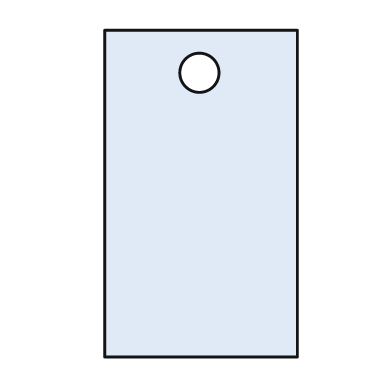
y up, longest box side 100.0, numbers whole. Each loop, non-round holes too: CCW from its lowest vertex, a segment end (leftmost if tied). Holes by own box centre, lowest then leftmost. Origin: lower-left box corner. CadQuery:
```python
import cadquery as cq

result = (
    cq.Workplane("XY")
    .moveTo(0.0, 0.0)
    .lineTo(59.0, 0.0)
    .lineTo(59.0, 100.0)
    .lineTo(0.0, 100.0)
    .close()
    .moveTo(29.0, 87.0)
    .circle(6.0)
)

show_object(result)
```